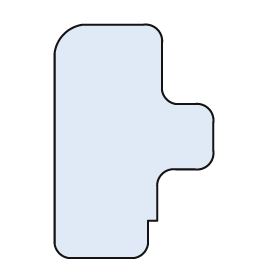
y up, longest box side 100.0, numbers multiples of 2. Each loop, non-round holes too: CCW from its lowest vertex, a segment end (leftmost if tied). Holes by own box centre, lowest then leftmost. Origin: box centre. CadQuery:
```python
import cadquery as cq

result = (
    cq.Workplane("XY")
    .moveTo(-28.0, -50.0)
    .lineTo(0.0, -50.0)
    .threePointArc((4.0, -48.0), (6.0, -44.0))
    .lineTo(6.0, -34.0)
    .lineTo(10.0, -34.0)
    .lineTo(10.0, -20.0)
    .threePointArc((12.0, -14.0), (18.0, -12.0))
    .lineTo(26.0, -12.0)
    .threePointArc((32.0, -10.0), (34.0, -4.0))
    .lineTo(34.0, 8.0)
    .threePointArc((32.0, 14.0), (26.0, 16.0))
    .lineTo(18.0, 16.0)
    .threePointArc((14.0, 18.0), (12.0, 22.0))
    .lineTo(12.0, 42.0)
    .threePointArc((10.0, 48.0), (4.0, 50.0))
    .lineTo(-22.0, 50.0)
    .threePointArc((-30.0, 46.0), (-34.0, 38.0))
    .lineTo(-34.0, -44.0)
    .threePointArc((-32.0, -48.0), (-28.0, -50.0))
    .close()
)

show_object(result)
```